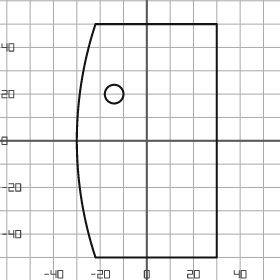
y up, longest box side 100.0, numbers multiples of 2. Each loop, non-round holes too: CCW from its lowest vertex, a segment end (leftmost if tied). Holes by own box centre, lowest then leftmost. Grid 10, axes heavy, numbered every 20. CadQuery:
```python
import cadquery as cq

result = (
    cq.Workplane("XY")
    .moveTo(-22.0, -50.0)
    .lineTo(30.0, -50.0)
    .lineTo(30.0, 50.0)
    .lineTo(-22.0, 50.0)
    .threePointArc((-30.0, 0.0), (-22.0, -50.0))
    .close()
    .moveTo(-14.0, 20.0)
    .circle(4.0)
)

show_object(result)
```